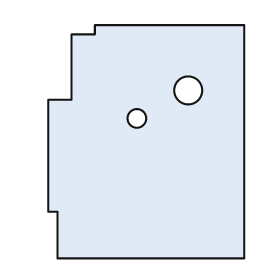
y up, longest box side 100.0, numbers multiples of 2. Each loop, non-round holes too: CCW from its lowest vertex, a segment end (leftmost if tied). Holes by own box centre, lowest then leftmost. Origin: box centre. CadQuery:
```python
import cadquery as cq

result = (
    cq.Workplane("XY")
    .moveTo(-38.0, -50.0)
    .lineTo(42.0, -50.0)
    .lineTo(42.0, 50.0)
    .lineTo(-22.0, 50.0)
    .lineTo(-22.0, 46.0)
    .lineTo(-32.0, 46.0)
    .lineTo(-32.0, 18.0)
    .lineTo(-42.0, 18.0)
    .lineTo(-42.0, -30.0)
    .lineTo(-38.0, -30.0)
    .close()
    .moveTo(-4.0, 10.0)
    .circle(4.0)
    .moveTo(18.0, 22.0)
    .circle(6.0)
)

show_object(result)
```